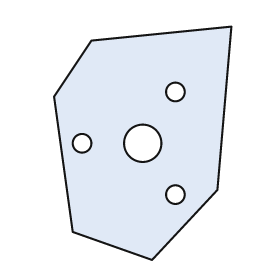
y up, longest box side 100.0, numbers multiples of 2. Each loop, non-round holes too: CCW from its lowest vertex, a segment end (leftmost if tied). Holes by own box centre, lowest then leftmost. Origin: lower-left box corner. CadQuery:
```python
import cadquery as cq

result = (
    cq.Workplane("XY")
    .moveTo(42.0, 0.0)
    .lineTo(70.0, 30.0)
    .lineTo(76.0, 100.0)
    .lineTo(16.0, 94.0)
    .lineTo(0.0, 70.0)
    .lineTo(8.0, 12.0)
    .close()
    .moveTo(52.0, 28.0)
    .circle(4.0)
    .moveTo(12.0, 50.0)
    .circle(4.0)
    .moveTo(38.0, 50.0)
    .circle(8.0)
    .moveTo(52.0, 72.0)
    .circle(4.0)
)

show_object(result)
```